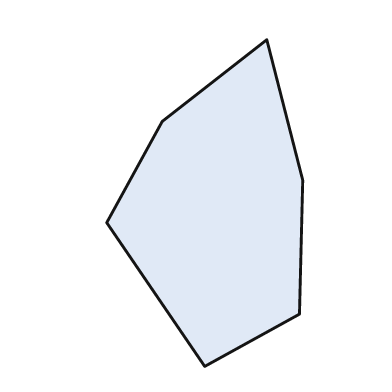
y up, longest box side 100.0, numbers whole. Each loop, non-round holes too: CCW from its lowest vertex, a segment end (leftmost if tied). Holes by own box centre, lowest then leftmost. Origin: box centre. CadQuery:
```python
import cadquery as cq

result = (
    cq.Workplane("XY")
    .moveTo(0.0, -50.0)
    .lineTo(29.0, -34.0)
    .lineTo(30.0, 7.0)
    .lineTo(19.0, 50.0)
    .lineTo(-13.0, 25.0)
    .lineTo(-30.0, -6.0)
    .close()
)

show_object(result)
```